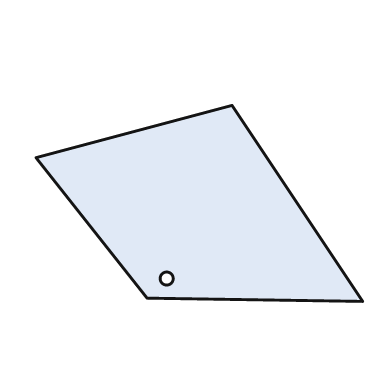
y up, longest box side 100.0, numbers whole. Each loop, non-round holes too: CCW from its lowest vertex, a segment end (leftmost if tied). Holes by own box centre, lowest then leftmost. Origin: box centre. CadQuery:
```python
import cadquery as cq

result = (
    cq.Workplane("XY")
    .moveTo(50.0, -30.0)
    .lineTo(10.0, 30.0)
    .lineTo(-50.0, 14.0)
    .lineTo(-16.0, -29.0)
    .close()
    .moveTo(-10.0, -23.0)
    .circle(2.0)
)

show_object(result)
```